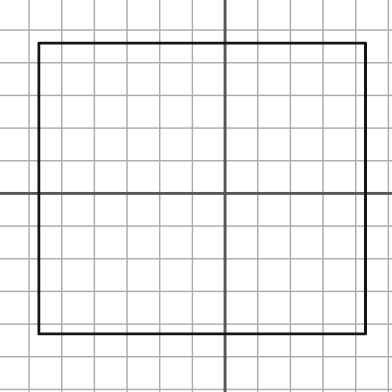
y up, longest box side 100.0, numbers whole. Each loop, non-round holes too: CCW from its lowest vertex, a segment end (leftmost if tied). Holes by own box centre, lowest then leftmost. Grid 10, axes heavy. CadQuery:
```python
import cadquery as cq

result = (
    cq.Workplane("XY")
    .moveTo(-57.0, -43.0)
    .lineTo(43.0, -43.0)
    .lineTo(43.0, 46.0)
    .lineTo(-57.0, 46.0)
    .close()
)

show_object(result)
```